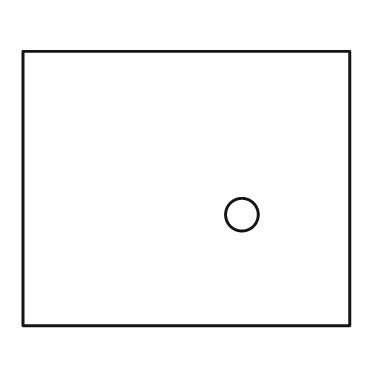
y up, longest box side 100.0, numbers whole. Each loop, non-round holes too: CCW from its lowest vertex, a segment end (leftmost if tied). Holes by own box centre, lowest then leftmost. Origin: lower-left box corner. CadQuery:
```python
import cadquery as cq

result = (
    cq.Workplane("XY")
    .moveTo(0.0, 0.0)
    .lineTo(100.0, 0.0)
    .lineTo(100.0, 84.0)
    .lineTo(0.0, 84.0)
    .close()
    .moveTo(67.0, 34.0)
    .circle(5.0)
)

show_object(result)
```